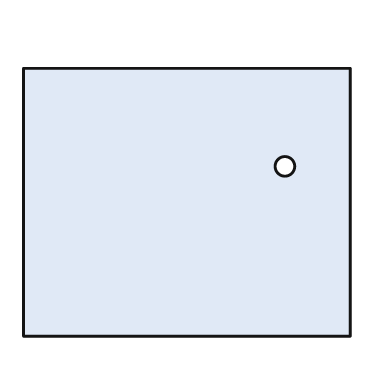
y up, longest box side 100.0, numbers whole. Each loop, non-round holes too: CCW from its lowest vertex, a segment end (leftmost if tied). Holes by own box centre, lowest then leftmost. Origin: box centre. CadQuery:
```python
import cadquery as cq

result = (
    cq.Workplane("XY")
    .moveTo(-50.0, -41.0)
    .lineTo(50.0, -41.0)
    .lineTo(50.0, 41.0)
    .lineTo(-50.0, 41.0)
    .close()
    .moveTo(30.0, 11.0)
    .circle(3.0)
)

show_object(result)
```